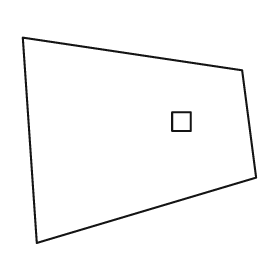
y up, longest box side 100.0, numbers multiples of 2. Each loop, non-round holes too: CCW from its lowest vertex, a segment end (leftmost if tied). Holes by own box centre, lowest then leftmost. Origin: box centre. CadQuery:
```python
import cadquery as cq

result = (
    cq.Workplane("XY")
    .moveTo(-44.0, -44.0)
    .lineTo(50.0, -16.0)
    .lineTo(44.0, 30.0)
    .lineTo(-50.0, 44.0)
    .close()
    .moveTo(14.0, 4.0)
    .lineTo(22.0, 4.0)
    .lineTo(22.0, 12.0)
    .lineTo(14.0, 12.0)
    .close()
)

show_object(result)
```